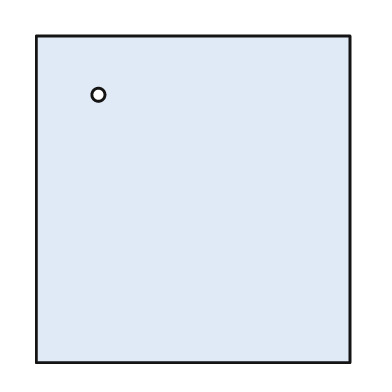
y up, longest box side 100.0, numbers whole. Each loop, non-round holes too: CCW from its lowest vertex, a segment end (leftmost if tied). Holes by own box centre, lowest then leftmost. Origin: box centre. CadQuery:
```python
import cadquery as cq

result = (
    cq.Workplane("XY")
    .moveTo(-48.0, -50.0)
    .lineTo(48.0, -50.0)
    .lineTo(48.0, 50.0)
    .lineTo(-48.0, 50.0)
    .close()
    .moveTo(-29.0, 32.0)
    .circle(2.0)
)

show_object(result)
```